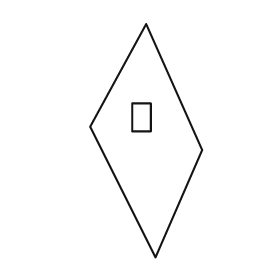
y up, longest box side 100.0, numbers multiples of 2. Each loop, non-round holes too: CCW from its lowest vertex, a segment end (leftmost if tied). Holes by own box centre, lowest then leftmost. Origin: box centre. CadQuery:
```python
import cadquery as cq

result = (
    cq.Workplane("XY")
    .moveTo(4.0, -50.0)
    .lineTo(24.0, -4.0)
    .lineTo(0.0, 50.0)
    .lineTo(-24.0, 6.0)
    .close()
    .moveTo(-6.0, 4.0)
    .lineTo(2.0, 4.0)
    .lineTo(2.0, 16.0)
    .lineTo(-6.0, 16.0)
    .close()
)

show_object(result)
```